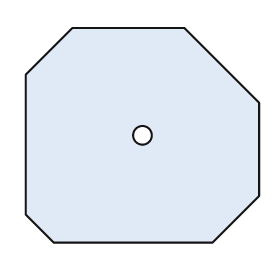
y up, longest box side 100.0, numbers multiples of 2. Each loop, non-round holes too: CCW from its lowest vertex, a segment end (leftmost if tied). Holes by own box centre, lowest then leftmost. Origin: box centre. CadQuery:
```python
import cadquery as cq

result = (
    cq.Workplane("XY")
    .moveTo(-38.0, -46.0)
    .lineTo(30.0, -46.0)
    .lineTo(50.0, -26.0)
    .lineTo(50.0, 14.0)
    .lineTo(18.0, 46.0)
    .lineTo(-30.0, 46.0)
    .lineTo(-50.0, 26.0)
    .lineTo(-50.0, -34.0)
    .close()
    .moveTo(0.0, 0.0)
    .circle(4.0)
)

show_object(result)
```